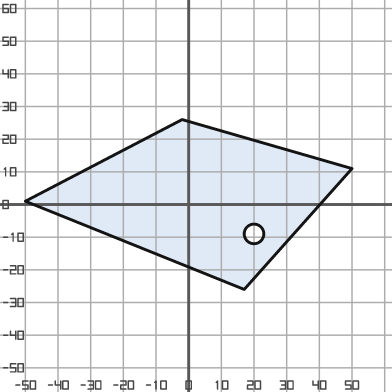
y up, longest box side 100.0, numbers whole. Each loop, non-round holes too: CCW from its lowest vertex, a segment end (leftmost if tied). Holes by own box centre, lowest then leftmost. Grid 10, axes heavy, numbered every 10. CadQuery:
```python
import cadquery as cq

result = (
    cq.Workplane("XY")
    .moveTo(17.0, -26.0)
    .lineTo(50.0, 11.0)
    .lineTo(-2.0, 26.0)
    .lineTo(-50.0, 1.0)
    .close()
    .moveTo(20.0, -9.0)
    .circle(3.0)
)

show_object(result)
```